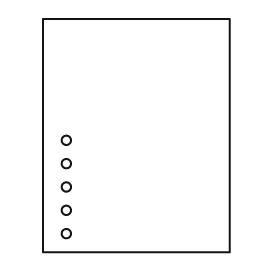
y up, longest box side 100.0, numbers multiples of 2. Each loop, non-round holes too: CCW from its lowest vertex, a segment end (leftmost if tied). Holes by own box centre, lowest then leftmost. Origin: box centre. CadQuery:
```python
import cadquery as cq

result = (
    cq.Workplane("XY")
    .moveTo(-40.0, -50.0)
    .lineTo(40.0, -50.0)
    .lineTo(40.0, 50.0)
    .lineTo(-40.0, 50.0)
    .close()
    .moveTo(-30.0, -42.0)
    .circle(2.0)
    .moveTo(-30.0, -32.0)
    .circle(2.0)
    .moveTo(-30.0, -22.0)
    .circle(2.0)
    .moveTo(-30.0, -12.0)
    .circle(2.0)
    .moveTo(-30.0, -2.0)
    .circle(2.0)
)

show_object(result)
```